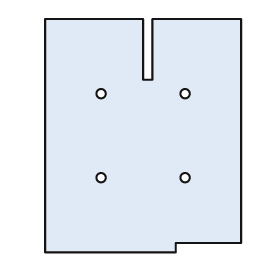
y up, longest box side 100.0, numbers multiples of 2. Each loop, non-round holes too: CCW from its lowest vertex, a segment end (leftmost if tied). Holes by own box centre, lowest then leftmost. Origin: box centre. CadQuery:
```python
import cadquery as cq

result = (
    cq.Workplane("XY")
    .moveTo(-42.0, -50.0)
    .lineTo(14.0, -50.0)
    .lineTo(14.0, -46.0)
    .lineTo(42.0, -46.0)
    .lineTo(42.0, 50.0)
    .lineTo(4.0, 50.0)
    .lineTo(4.0, 24.0)
    .lineTo(0.0, 24.0)
    .lineTo(0.0, 50.0)
    .lineTo(-42.0, 50.0)
    .close()
    .moveTo(-18.0, -18.0)
    .circle(2.0)
    .moveTo(18.0, -18.0)
    .circle(2.0)
    .moveTo(-18.0, 18.0)
    .circle(2.0)
    .moveTo(18.0, 18.0)
    .circle(2.0)
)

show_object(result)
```